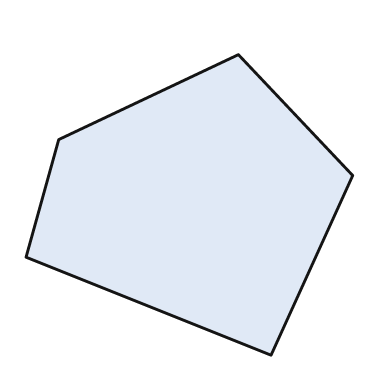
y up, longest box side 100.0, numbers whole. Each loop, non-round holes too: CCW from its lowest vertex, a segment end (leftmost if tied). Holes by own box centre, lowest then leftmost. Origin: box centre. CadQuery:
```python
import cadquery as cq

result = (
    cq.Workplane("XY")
    .moveTo(25.0, -46.0)
    .lineTo(50.0, 9.0)
    .lineTo(15.0, 46.0)
    .lineTo(-40.0, 20.0)
    .lineTo(-50.0, -16.0)
    .close()
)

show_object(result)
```